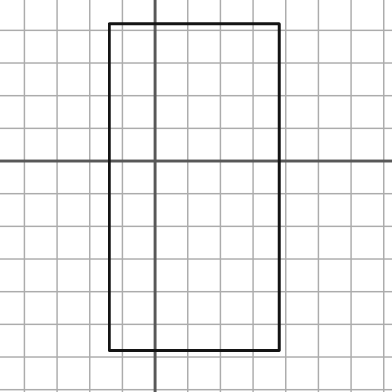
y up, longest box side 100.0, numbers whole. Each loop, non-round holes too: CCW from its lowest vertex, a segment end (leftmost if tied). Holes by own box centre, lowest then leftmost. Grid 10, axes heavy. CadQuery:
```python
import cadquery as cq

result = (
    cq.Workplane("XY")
    .moveTo(-14.0, -58.0)
    .lineTo(38.0, -58.0)
    .lineTo(38.0, 42.0)
    .lineTo(-14.0, 42.0)
    .close()
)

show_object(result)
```